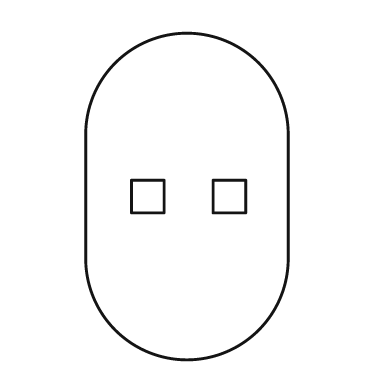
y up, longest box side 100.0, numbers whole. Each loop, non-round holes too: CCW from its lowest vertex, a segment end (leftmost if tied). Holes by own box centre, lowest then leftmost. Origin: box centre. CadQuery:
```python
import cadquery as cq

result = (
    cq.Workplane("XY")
    .moveTo(-31.0, -19.0)
    .threePointArc((0.0, -50.0), (31.0, -19.0))
    .lineTo(31.0, 19.0)
    .threePointArc((0.0, 50.0), (-31.0, 19.0))
    .close()
    .moveTo(-17.0, -5.0)
    .lineTo(-7.0, -5.0)
    .lineTo(-7.0, 5.0)
    .lineTo(-17.0, 5.0)
    .close()
    .moveTo(8.0, -5.0)
    .lineTo(18.0, -5.0)
    .lineTo(18.0, 5.0)
    .lineTo(8.0, 5.0)
    .close()
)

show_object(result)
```